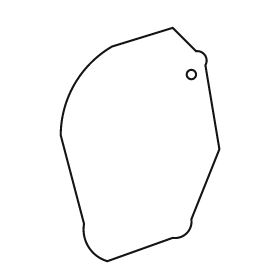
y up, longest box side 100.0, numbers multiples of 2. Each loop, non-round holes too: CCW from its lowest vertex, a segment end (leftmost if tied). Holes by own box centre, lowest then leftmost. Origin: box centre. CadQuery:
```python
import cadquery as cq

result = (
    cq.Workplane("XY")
    .moveTo(-14.0, -50.0)
    .lineTo(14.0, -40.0)
    .threePointArc((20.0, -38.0), (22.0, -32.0))
    .lineTo(34.0, -2.0)
    .lineTo(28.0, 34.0)
    .threePointArc((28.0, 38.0), (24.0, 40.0))
    .lineTo(14.0, 50.0)
    .lineTo(-12.0, 42.0)
    .threePointArc((-28.0, 26.0), (-34.0, 4.0))
    .lineTo(-24.0, -34.0)
    .threePointArc((-22.0, -44.0), (-14.0, -50.0))
    .close()
    .moveTo(22.0, 30.0)
    .circle(2.0)
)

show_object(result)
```